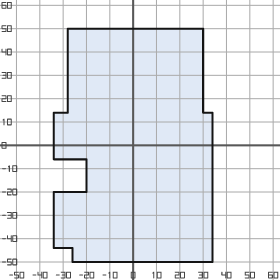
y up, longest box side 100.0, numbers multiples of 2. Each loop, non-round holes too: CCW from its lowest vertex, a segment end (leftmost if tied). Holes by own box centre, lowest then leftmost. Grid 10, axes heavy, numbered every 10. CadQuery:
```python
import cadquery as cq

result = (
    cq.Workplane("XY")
    .moveTo(-26.0, -50.0)
    .lineTo(34.0, -50.0)
    .lineTo(34.0, 14.0)
    .lineTo(30.0, 14.0)
    .lineTo(30.0, 50.0)
    .lineTo(-28.0, 50.0)
    .lineTo(-28.0, 14.0)
    .lineTo(-34.0, 14.0)
    .lineTo(-34.0, -6.0)
    .lineTo(-20.0, -6.0)
    .lineTo(-20.0, -20.0)
    .lineTo(-34.0, -20.0)
    .lineTo(-34.0, -44.0)
    .lineTo(-26.0, -44.0)
    .close()
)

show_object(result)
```